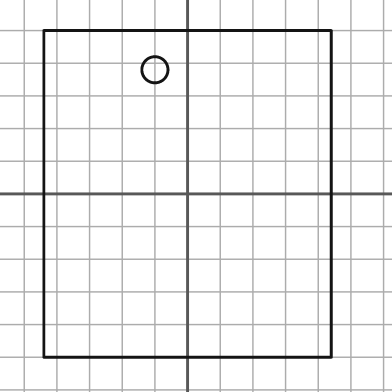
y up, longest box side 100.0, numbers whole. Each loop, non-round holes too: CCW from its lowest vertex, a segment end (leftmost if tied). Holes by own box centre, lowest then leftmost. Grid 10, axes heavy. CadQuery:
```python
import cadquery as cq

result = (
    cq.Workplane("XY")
    .moveTo(-44.0, -50.0)
    .lineTo(44.0, -50.0)
    .lineTo(44.0, 50.0)
    .lineTo(-44.0, 50.0)
    .close()
    .moveTo(-10.0, 38.0)
    .circle(4.0)
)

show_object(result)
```